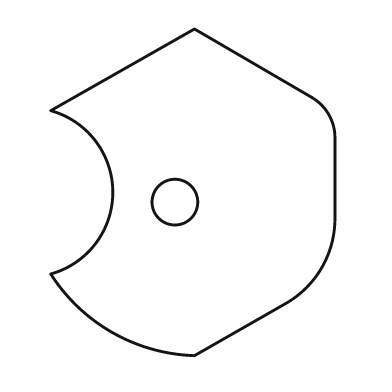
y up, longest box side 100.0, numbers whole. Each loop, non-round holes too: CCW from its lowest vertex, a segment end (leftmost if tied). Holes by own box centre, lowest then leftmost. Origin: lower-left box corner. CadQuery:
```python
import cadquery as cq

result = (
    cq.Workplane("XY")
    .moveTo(44.0, 0.0)
    .lineTo(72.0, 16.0)
    .threePointArc((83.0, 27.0), (87.0, 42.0))
    .lineTo(87.0, 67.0)
    .threePointArc((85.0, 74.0), (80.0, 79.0))
    .lineTo(44.0, 100.0)
    .lineTo(0.0, 75.0)
    .threePointArc((19.0, 50.0), (0.0, 25.0))
    .threePointArc((19.0, 7.0), (44.0, 0.0))
    .close()
    .moveTo(38.0, 47.0)
    .circle(7.0)
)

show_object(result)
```